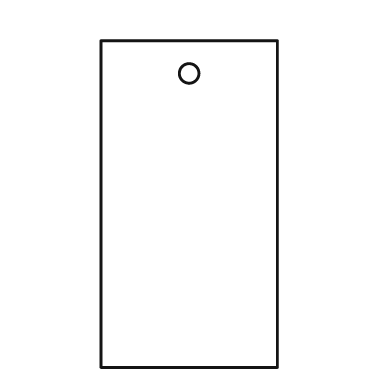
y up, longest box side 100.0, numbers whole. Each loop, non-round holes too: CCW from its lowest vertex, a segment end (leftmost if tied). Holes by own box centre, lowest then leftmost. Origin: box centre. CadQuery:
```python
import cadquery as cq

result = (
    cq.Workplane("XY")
    .moveTo(-27.0, -50.0)
    .lineTo(27.0, -50.0)
    .lineTo(27.0, 50.0)
    .lineTo(-27.0, 50.0)
    .close()
    .moveTo(0.0, 40.0)
    .circle(3.0)
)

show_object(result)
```